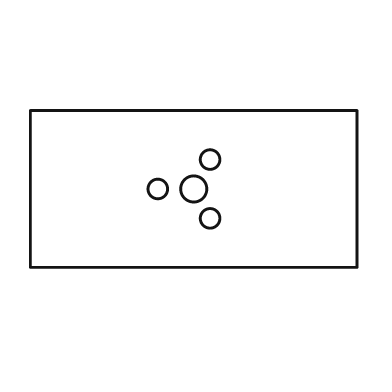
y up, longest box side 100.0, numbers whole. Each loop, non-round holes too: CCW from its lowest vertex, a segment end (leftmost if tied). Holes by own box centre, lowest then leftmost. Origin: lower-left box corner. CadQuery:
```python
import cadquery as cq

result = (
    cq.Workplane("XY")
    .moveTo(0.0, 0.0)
    .lineTo(100.0, 0.0)
    .lineTo(100.0, 48.0)
    .lineTo(0.0, 48.0)
    .close()
    .moveTo(55.0, 15.0)
    .circle(3.0)
    .moveTo(39.0, 24.0)
    .circle(3.0)
    .moveTo(50.0, 24.0)
    .circle(4.0)
    .moveTo(55.0, 33.0)
    .circle(3.0)
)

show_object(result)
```